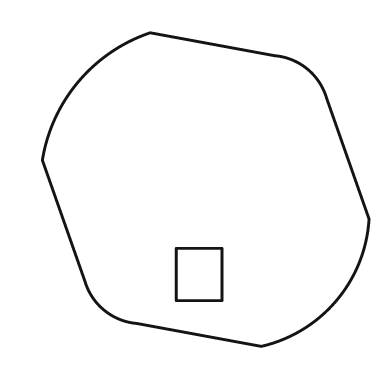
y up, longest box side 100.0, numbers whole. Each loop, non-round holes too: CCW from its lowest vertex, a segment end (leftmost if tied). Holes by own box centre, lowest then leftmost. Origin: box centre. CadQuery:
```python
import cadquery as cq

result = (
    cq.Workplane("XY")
    .moveTo(17.0, -48.0)
    .threePointArc((40.0, -34.0), (50.0, -9.0))
    .lineTo(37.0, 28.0)
    .threePointArc((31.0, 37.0), (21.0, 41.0))
    .lineTo(-17.0, 48.0)
    .threePointArc((-39.0, 33.0), (-50.0, 9.0))
    .lineTo(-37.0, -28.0)
    .threePointArc((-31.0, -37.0), (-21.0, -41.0))
    .close()
    .moveTo(-9.0, -34.0)
    .lineTo(5.0, -34.0)
    .lineTo(5.0, -18.0)
    .lineTo(-9.0, -18.0)
    .close()
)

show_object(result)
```